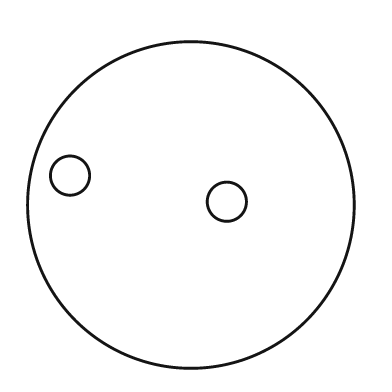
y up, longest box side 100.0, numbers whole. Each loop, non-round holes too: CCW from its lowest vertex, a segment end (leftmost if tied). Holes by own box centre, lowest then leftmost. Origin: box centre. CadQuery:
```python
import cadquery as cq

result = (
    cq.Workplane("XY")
    .moveTo(0.0, 0.0)
    .circle(50.0)
    .moveTo(11.0, 1.0)
    .circle(6.0)
    .moveTo(-37.0, 9.0)
    .circle(6.0)
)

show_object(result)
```